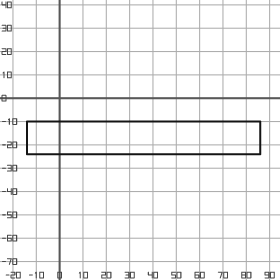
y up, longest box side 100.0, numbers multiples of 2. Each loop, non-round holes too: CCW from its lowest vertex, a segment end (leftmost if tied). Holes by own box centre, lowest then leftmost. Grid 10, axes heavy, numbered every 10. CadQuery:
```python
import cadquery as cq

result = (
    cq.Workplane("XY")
    .moveTo(-14.0, -24.0)
    .lineTo(86.0, -24.0)
    .lineTo(86.0, -10.0)
    .lineTo(-14.0, -10.0)
    .close()
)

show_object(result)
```